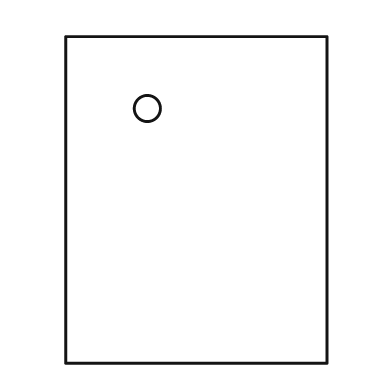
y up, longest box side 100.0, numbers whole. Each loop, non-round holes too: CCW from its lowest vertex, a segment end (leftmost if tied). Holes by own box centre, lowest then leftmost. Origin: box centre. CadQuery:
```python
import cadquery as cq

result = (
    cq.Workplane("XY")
    .moveTo(-40.0, -50.0)
    .lineTo(40.0, -50.0)
    .lineTo(40.0, 50.0)
    .lineTo(-40.0, 50.0)
    .close()
    .moveTo(-15.0, 28.0)
    .circle(4.0)
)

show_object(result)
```